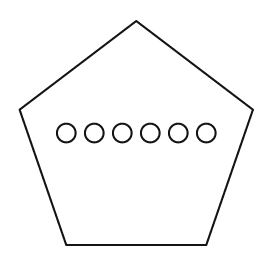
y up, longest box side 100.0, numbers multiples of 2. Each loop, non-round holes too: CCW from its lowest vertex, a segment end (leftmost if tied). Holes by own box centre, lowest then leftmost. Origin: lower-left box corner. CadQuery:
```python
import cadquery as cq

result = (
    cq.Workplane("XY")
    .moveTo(20.0, 0.0)
    .lineTo(80.0, 0.0)
    .lineTo(100.0, 58.0)
    .lineTo(50.0, 96.0)
    .lineTo(0.0, 58.0)
    .close()
    .moveTo(20.0, 48.0)
    .circle(4.0)
    .moveTo(32.0, 48.0)
    .circle(4.0)
    .moveTo(44.0, 48.0)
    .circle(4.0)
    .moveTo(56.0, 48.0)
    .circle(4.0)
    .moveTo(68.0, 48.0)
    .circle(4.0)
    .moveTo(80.0, 48.0)
    .circle(4.0)
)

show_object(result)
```